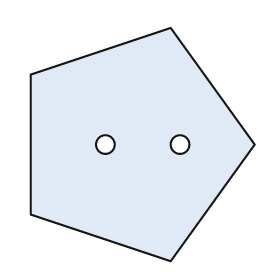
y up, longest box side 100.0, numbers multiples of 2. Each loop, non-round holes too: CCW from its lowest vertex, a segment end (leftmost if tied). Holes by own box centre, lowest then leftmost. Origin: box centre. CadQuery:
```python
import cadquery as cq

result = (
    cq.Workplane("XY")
    .moveTo(12.0, -50.0)
    .lineTo(48.0, 0.0)
    .lineTo(12.0, 50.0)
    .lineTo(-48.0, 30.0)
    .lineTo(-48.0, -30.0)
    .close()
    .moveTo(-16.0, 0.0)
    .circle(4.0)
    .moveTo(16.0, 0.0)
    .circle(4.0)
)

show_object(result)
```